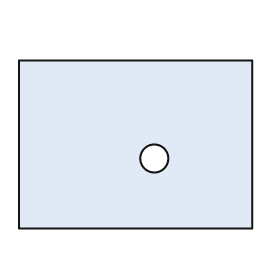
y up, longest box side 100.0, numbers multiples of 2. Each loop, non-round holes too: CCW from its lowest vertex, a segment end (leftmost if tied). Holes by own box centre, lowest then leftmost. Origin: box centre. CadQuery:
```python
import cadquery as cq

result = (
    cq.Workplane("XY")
    .moveTo(-50.0, -36.0)
    .lineTo(50.0, -36.0)
    .lineTo(50.0, 36.0)
    .lineTo(-50.0, 36.0)
    .close()
    .moveTo(8.0, -6.0)
    .circle(6.0)
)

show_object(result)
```